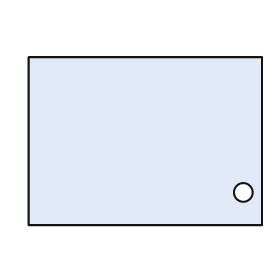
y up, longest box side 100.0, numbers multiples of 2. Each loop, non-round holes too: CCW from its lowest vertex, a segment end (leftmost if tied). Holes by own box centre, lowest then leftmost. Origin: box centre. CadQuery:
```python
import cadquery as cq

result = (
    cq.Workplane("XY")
    .moveTo(-50.0, -36.0)
    .lineTo(50.0, -36.0)
    .lineTo(50.0, 36.0)
    .lineTo(-50.0, 36.0)
    .close()
    .moveTo(42.0, -22.0)
    .circle(4.0)
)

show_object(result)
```